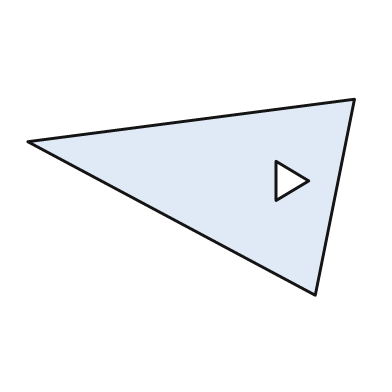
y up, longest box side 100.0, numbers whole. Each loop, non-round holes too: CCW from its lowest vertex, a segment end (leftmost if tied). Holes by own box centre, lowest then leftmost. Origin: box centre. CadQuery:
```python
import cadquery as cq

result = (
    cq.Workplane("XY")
    .moveTo(38.0, -30.0)
    .lineTo(50.0, 30.0)
    .lineTo(-50.0, 17.0)
    .close()
    .moveTo(26.0, -1.0)
    .lineTo(36.0, 5.0)
    .lineTo(26.0, 11.0)
    .close()
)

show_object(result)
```